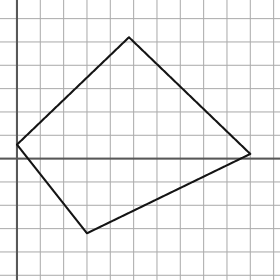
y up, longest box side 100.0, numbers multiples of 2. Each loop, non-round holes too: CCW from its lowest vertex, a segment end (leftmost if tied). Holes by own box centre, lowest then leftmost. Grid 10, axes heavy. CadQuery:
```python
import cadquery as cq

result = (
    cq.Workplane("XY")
    .moveTo(30.0, -32.0)
    .lineTo(100.0, 2.0)
    .lineTo(48.0, 52.0)
    .lineTo(0.0, 6.0)
    .close()
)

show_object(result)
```